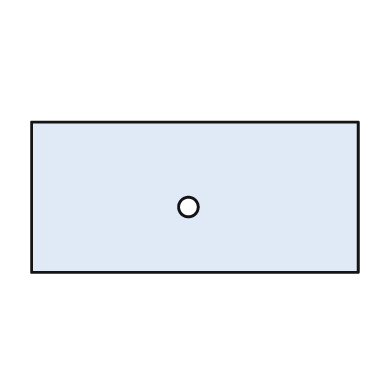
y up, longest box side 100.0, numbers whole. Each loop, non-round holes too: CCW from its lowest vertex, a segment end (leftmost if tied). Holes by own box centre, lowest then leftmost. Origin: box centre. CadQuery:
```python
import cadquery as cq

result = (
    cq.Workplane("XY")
    .moveTo(-50.0, -23.0)
    .lineTo(50.0, -23.0)
    .lineTo(50.0, 23.0)
    .lineTo(-50.0, 23.0)
    .close()
    .moveTo(-2.0, -3.0)
    .circle(3.0)
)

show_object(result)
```